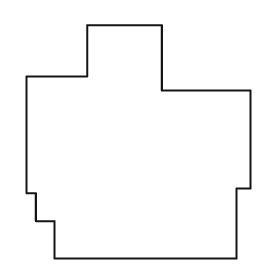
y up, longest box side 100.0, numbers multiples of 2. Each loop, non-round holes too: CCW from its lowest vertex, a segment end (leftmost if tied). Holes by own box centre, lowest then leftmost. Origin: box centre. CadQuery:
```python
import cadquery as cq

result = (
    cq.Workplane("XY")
    .moveTo(-36.0, -50.0)
    .lineTo(42.0, -50.0)
    .lineTo(42.0, -20.0)
    .lineTo(48.0, -20.0)
    .lineTo(48.0, 22.0)
    .lineTo(10.0, 22.0)
    .lineTo(10.0, 50.0)
    .lineTo(-22.0, 50.0)
    .lineTo(-22.0, 28.0)
    .lineTo(-48.0, 28.0)
    .lineTo(-48.0, -22.0)
    .lineTo(-44.0, -22.0)
    .lineTo(-44.0, -34.0)
    .lineTo(-36.0, -34.0)
    .close()
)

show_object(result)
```